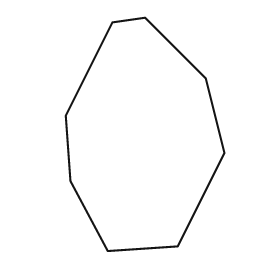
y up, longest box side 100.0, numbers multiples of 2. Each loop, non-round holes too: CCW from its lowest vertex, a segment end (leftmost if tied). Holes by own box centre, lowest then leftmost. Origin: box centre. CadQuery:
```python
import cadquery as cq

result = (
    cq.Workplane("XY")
    .moveTo(-16.0, -50.0)
    .lineTo(14.0, -48.0)
    .lineTo(34.0, -8.0)
    .lineTo(26.0, 24.0)
    .lineTo(0.0, 50.0)
    .lineTo(-14.0, 48.0)
    .lineTo(-34.0, 8.0)
    .lineTo(-32.0, -20.0)
    .close()
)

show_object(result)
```